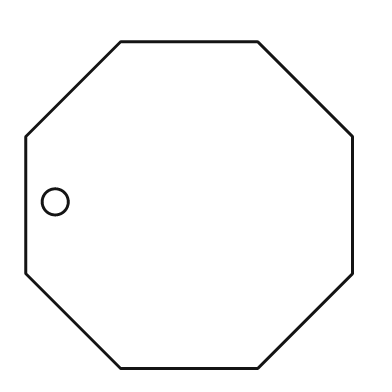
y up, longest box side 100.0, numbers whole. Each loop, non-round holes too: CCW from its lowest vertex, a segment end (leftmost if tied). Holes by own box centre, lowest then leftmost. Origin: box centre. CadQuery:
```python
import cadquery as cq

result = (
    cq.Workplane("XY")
    .moveTo(-21.0, -50.0)
    .lineTo(21.0, -50.0)
    .lineTo(50.0, -21.0)
    .lineTo(50.0, 21.0)
    .lineTo(21.0, 50.0)
    .lineTo(-21.0, 50.0)
    .lineTo(-50.0, 21.0)
    .lineTo(-50.0, -21.0)
    .close()
    .moveTo(-41.0, 1.0)
    .circle(4.0)
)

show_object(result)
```